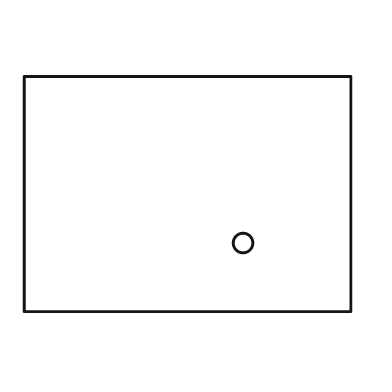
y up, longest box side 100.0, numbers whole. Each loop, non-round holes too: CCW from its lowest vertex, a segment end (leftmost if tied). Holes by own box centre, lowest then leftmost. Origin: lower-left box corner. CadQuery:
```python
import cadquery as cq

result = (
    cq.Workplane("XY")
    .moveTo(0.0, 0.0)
    .lineTo(100.0, 0.0)
    .lineTo(100.0, 72.0)
    .lineTo(0.0, 72.0)
    .close()
    .moveTo(67.0, 21.0)
    .circle(3.0)
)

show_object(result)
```